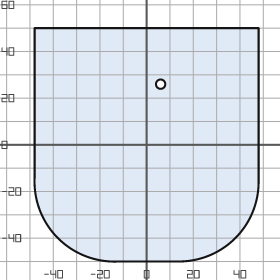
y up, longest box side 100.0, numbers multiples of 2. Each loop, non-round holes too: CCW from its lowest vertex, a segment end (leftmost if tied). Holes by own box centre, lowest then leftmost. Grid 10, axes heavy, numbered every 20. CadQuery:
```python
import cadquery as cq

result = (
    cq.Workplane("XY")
    .moveTo(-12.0, -50.0)
    .lineTo(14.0, -50.0)
    .threePointArc((38.0, -40.0), (48.0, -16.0))
    .lineTo(48.0, 50.0)
    .lineTo(-48.0, 50.0)
    .lineTo(-48.0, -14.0)
    .threePointArc((-38.0, -40.0), (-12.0, -50.0))
    .close()
    .moveTo(6.0, 26.0)
    .circle(2.0)
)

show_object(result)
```